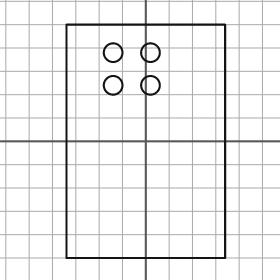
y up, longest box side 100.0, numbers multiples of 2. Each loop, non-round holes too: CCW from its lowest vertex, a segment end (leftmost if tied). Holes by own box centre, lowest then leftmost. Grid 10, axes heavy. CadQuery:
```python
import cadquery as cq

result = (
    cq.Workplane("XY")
    .moveTo(-34.0, -50.0)
    .lineTo(34.0, -50.0)
    .lineTo(34.0, 50.0)
    .lineTo(-34.0, 50.0)
    .close()
    .moveTo(-14.0, 24.0)
    .circle(4.0)
    .moveTo(2.0, 24.0)
    .circle(4.0)
    .moveTo(-14.0, 38.0)
    .circle(4.0)
    .moveTo(2.0, 38.0)
    .circle(4.0)
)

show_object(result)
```